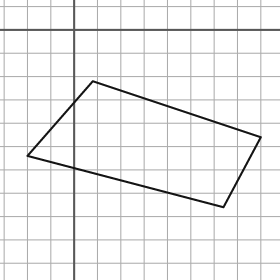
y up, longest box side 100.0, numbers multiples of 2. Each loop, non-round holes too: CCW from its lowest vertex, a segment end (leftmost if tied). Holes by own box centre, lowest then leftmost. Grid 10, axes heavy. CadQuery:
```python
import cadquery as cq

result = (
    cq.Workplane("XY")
    .moveTo(64.0, -76.0)
    .lineTo(80.0, -46.0)
    .lineTo(8.0, -22.0)
    .lineTo(-20.0, -54.0)
    .close()
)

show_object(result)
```